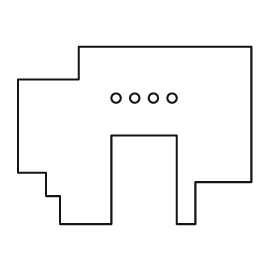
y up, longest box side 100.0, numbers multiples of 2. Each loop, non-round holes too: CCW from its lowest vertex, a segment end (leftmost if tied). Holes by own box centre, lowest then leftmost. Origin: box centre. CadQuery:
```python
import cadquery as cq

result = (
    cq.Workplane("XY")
    .moveTo(-32.0, -38.0)
    .lineTo(-10.0, -38.0)
    .lineTo(-10.0, 0.0)
    .lineTo(18.0, 0.0)
    .lineTo(18.0, -38.0)
    .lineTo(26.0, -38.0)
    .lineTo(26.0, -20.0)
    .lineTo(50.0, -20.0)
    .lineTo(50.0, 38.0)
    .lineTo(-24.0, 38.0)
    .lineTo(-24.0, 24.0)
    .lineTo(-50.0, 24.0)
    .lineTo(-50.0, -16.0)
    .lineTo(-38.0, -16.0)
    .lineTo(-38.0, -26.0)
    .lineTo(-32.0, -26.0)
    .close()
    .moveTo(-8.0, 16.0)
    .circle(2.0)
    .moveTo(0.0, 16.0)
    .circle(2.0)
    .moveTo(8.0, 16.0)
    .circle(2.0)
    .moveTo(16.0, 16.0)
    .circle(2.0)
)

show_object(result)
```